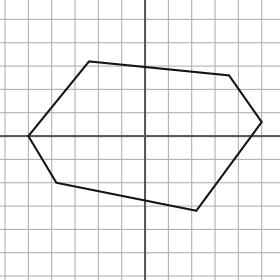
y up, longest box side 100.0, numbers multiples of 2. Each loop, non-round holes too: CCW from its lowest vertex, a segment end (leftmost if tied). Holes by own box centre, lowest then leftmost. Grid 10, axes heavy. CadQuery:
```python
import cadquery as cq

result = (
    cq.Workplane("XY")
    .moveTo(22.0, -32.0)
    .lineTo(50.0, 6.0)
    .lineTo(36.0, 26.0)
    .lineTo(-24.0, 32.0)
    .lineTo(-50.0, 0.0)
    .lineTo(-38.0, -20.0)
    .close()
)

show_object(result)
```